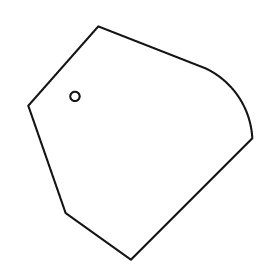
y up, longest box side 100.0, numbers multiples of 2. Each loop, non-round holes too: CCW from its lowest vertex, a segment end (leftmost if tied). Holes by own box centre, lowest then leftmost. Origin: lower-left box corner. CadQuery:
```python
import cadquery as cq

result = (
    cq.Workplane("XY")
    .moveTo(44.0, 0.0)
    .lineTo(96.0, 52.0)
    .threePointArc((90.0, 70.0), (76.0, 82.0))
    .lineTo(30.0, 100.0)
    .lineTo(0.0, 66.0)
    .lineTo(16.0, 20.0)
    .close()
    .moveTo(20.0, 70.0)
    .circle(2.0)
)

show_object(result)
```